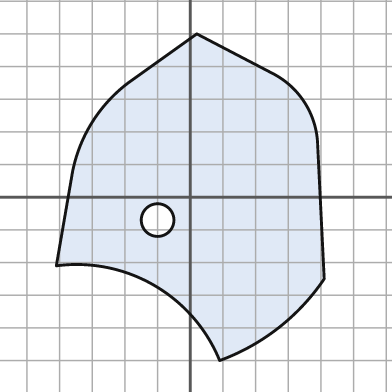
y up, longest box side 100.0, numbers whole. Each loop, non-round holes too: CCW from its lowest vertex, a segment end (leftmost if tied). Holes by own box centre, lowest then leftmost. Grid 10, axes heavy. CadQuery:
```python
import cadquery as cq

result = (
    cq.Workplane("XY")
    .moveTo(9.0, -50.0)
    .threePointArc((27.0, -40.0), (41.0, -25.0))
    .lineTo(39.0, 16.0)
    .threePointArc((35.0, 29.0), (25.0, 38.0))
    .lineTo(2.0, 50.0)
    .lineTo(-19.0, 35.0)
    .threePointArc((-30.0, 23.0), (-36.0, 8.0))
    .lineTo(-41.0, -21.0)
    .threePointArc((-11.0, -27.0), (9.0, -50.0))
    .close()
    .moveTo(-10.0, -7.0)
    .circle(5.0)
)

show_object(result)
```